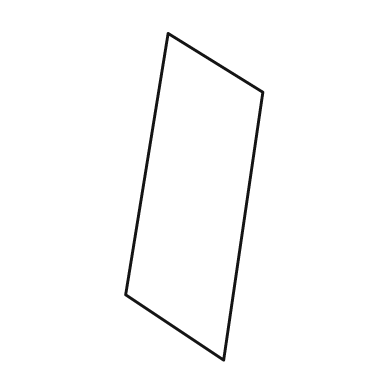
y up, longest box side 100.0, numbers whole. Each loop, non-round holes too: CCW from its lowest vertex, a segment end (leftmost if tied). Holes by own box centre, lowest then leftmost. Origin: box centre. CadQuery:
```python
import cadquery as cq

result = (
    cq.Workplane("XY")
    .moveTo(9.0, -50.0)
    .lineTo(21.0, 32.0)
    .lineTo(-8.0, 50.0)
    .lineTo(-21.0, -30.0)
    .close()
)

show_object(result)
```